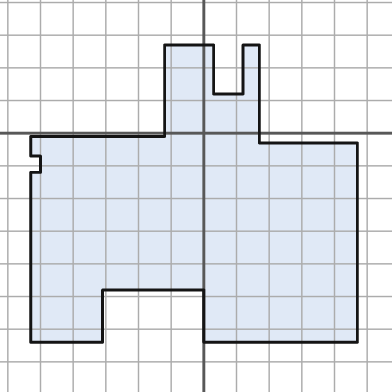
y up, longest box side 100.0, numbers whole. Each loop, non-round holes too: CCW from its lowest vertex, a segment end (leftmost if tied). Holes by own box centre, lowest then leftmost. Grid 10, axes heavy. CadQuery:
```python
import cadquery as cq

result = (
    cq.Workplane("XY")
    .moveTo(-53.0, -64.0)
    .lineTo(-31.0, -64.0)
    .lineTo(-31.0, -48.0)
    .lineTo(0.0, -48.0)
    .lineTo(0.0, -64.0)
    .lineTo(47.0, -64.0)
    .lineTo(47.0, -3.0)
    .lineTo(17.0, -3.0)
    .lineTo(17.0, 27.0)
    .lineTo(12.0, 27.0)
    .lineTo(12.0, 12.0)
    .lineTo(3.0, 12.0)
    .lineTo(3.0, 27.0)
    .lineTo(-12.0, 27.0)
    .lineTo(-12.0, -1.0)
    .lineTo(-53.0, -1.0)
    .lineTo(-53.0, -7.0)
    .lineTo(-50.0, -7.0)
    .lineTo(-50.0, -12.0)
    .lineTo(-53.0, -12.0)
    .close()
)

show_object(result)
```